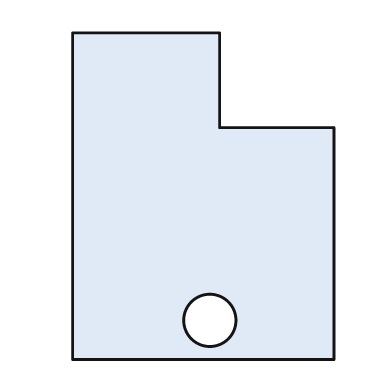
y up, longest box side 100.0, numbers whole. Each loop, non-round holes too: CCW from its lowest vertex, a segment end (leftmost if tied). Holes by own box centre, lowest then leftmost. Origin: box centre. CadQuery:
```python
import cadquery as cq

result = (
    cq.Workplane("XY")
    .moveTo(-40.0, -50.0)
    .lineTo(40.0, -50.0)
    .lineTo(40.0, 21.0)
    .lineTo(5.0, 21.0)
    .lineTo(5.0, 50.0)
    .lineTo(-40.0, 50.0)
    .close()
    .moveTo(2.0, -38.0)
    .circle(8.0)
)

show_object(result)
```